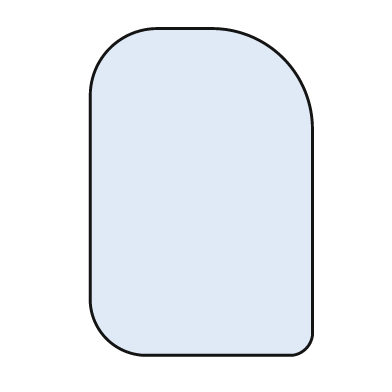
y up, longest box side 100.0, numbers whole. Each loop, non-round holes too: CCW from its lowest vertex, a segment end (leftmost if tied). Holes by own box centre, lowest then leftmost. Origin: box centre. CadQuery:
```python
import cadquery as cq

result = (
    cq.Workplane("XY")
    .moveTo(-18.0, -50.0)
    .lineTo(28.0, -50.0)
    .threePointArc((32.0, -48.0), (34.0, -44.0))
    .lineTo(34.0, 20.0)
    .threePointArc((25.0, 41.0), (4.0, 50.0))
    .lineTo(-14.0, 50.0)
    .threePointArc((-28.0, 44.0), (-34.0, 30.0))
    .lineTo(-34.0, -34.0)
    .threePointArc((-29.0, -45.0), (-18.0, -50.0))
    .close()
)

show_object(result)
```